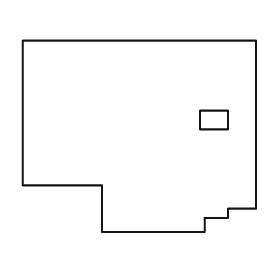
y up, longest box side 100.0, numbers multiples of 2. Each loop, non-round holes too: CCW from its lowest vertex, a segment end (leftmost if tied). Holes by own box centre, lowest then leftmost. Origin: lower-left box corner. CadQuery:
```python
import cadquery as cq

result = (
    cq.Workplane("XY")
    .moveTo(34.0, 0.0)
    .lineTo(78.0, 0.0)
    .lineTo(78.0, 6.0)
    .lineTo(88.0, 6.0)
    .lineTo(88.0, 10.0)
    .lineTo(100.0, 10.0)
    .lineTo(100.0, 82.0)
    .lineTo(0.0, 82.0)
    .lineTo(0.0, 20.0)
    .lineTo(34.0, 20.0)
    .close()
    .moveTo(76.0, 44.0)
    .lineTo(88.0, 44.0)
    .lineTo(88.0, 52.0)
    .lineTo(76.0, 52.0)
    .close()
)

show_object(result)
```